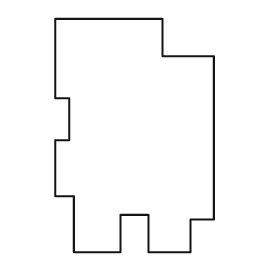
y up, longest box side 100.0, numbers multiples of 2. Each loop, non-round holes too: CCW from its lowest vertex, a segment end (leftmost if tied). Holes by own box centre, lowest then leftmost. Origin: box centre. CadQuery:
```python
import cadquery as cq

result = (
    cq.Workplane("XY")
    .moveTo(-26.0, -50.0)
    .lineTo(-6.0, -50.0)
    .lineTo(-6.0, -34.0)
    .lineTo(6.0, -34.0)
    .lineTo(6.0, -50.0)
    .lineTo(24.0, -50.0)
    .lineTo(24.0, -36.0)
    .lineTo(34.0, -36.0)
    .lineTo(34.0, 34.0)
    .lineTo(12.0, 34.0)
    .lineTo(12.0, 50.0)
    .lineTo(-34.0, 50.0)
    .lineTo(-34.0, 16.0)
    .lineTo(-28.0, 16.0)
    .lineTo(-28.0, -2.0)
    .lineTo(-34.0, -2.0)
    .lineTo(-34.0, -26.0)
    .lineTo(-26.0, -26.0)
    .close()
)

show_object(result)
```